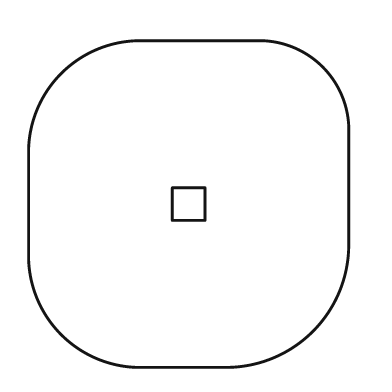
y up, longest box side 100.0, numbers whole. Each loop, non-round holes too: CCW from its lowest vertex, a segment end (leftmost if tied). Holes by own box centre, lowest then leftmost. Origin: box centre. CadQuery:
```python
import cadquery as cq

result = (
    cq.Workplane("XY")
    .moveTo(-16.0, -50.0)
    .lineTo(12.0, -50.0)
    .threePointArc((38.0, -39.0), (49.0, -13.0))
    .lineTo(49.0, 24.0)
    .threePointArc((41.0, 42.0), (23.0, 50.0))
    .lineTo(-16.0, 50.0)
    .threePointArc((-39.0, 40.0), (-49.0, 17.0))
    .lineTo(-49.0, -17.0)
    .threePointArc((-39.0, -40.0), (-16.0, -50.0))
    .close()
    .moveTo(-5.0, -5.0)
    .lineTo(5.0, -5.0)
    .lineTo(5.0, 5.0)
    .lineTo(-5.0, 5.0)
    .close()
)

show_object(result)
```